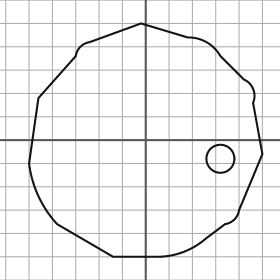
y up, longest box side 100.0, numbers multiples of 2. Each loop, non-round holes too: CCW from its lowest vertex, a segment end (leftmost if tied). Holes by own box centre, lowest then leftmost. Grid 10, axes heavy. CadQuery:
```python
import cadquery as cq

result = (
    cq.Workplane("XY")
    .moveTo(-14.0, -50.0)
    .lineTo(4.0, -50.0)
    .threePointArc((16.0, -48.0), (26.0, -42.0))
    .lineTo(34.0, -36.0)
    .threePointArc((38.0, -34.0), (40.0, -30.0))
    .lineTo(50.0, -6.0)
    .lineTo(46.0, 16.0)
    .threePointArc((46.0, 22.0), (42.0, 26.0))
    .lineTo(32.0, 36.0)
    .threePointArc((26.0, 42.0), (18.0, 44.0))
    .lineTo(-2.0, 50.0)
    .lineTo(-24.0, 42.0)
    .threePointArc((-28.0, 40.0), (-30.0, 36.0))
    .lineTo(-46.0, 18.0)
    .lineTo(-50.0, -10.0)
    .threePointArc((-46.0, -24.0), (-38.0, -36.0))
    .close()
    .moveTo(32.0, -8.0)
    .circle(6.0)
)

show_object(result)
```